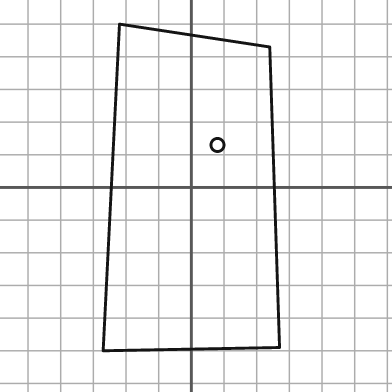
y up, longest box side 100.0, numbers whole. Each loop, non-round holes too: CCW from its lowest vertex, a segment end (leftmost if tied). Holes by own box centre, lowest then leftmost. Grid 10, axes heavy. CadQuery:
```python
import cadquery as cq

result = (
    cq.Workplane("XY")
    .moveTo(-27.0, -50.0)
    .lineTo(27.0, -49.0)
    .lineTo(24.0, 43.0)
    .lineTo(-22.0, 50.0)
    .close()
    .moveTo(8.0, 13.0)
    .circle(2.0)
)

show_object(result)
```